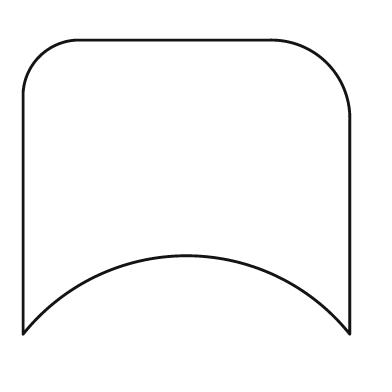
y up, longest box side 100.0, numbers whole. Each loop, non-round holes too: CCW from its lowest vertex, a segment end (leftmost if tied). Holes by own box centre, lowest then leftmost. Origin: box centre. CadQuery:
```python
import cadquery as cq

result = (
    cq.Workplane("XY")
    .moveTo(-50.0, -45.0)
    .threePointArc((0.0, -21.0), (50.0, -45.0))
    .lineTo(50.0, 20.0)
    .threePointArc((43.0, 38.0), (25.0, 45.0))
    .lineTo(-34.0, 45.0)
    .threePointArc((-45.0, 40.0), (-50.0, 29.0))
    .close()
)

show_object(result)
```